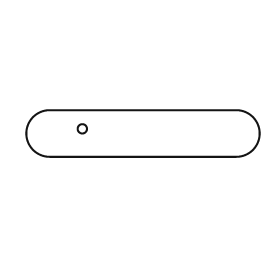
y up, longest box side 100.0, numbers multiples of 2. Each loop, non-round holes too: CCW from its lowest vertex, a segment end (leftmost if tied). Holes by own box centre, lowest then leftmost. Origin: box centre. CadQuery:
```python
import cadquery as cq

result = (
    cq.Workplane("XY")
    .moveTo(-40.0, -10.0)
    .lineTo(40.0, -10.0)
    .threePointArc((50.0, 0.0), (40.0, 10.0))
    .lineTo(-40.0, 10.0)
    .threePointArc((-50.0, 0.0), (-40.0, -10.0))
    .close()
    .moveTo(-26.0, 2.0)
    .circle(2.0)
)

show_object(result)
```